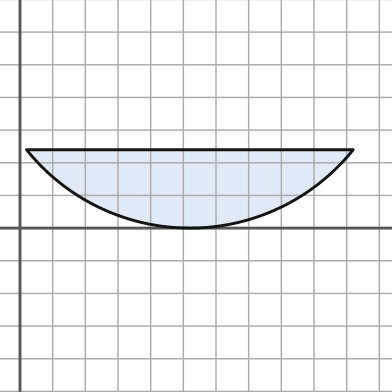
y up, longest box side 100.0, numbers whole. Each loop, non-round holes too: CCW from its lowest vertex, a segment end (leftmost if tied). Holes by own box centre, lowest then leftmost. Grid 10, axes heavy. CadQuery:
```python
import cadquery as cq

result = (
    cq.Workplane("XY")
    .moveTo(2.0, 24.0)
    .threePointArc((52.0, 0.0), (102.0, 24.0))
    .close()
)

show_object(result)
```